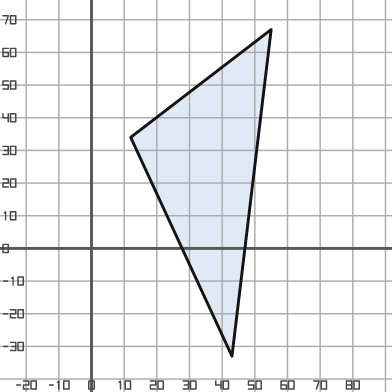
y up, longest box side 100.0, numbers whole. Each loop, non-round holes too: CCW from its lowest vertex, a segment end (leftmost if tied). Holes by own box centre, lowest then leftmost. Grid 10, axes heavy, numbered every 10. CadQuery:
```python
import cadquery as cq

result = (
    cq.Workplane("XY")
    .moveTo(43.0, -33.0)
    .lineTo(55.0, 67.0)
    .lineTo(12.0, 34.0)
    .close()
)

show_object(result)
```